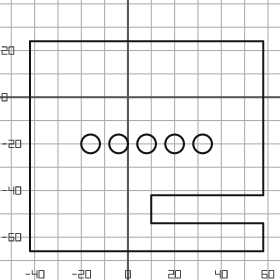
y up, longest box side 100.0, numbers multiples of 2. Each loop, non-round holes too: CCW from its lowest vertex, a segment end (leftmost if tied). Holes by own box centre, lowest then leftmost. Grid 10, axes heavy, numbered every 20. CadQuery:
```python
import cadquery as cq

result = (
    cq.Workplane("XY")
    .moveTo(-42.0, -66.0)
    .lineTo(58.0, -66.0)
    .lineTo(58.0, -54.0)
    .lineTo(10.0, -54.0)
    .lineTo(10.0, -42.0)
    .lineTo(58.0, -42.0)
    .lineTo(58.0, 24.0)
    .lineTo(-42.0, 24.0)
    .close()
    .moveTo(-16.0, -20.0)
    .circle(4.0)
    .moveTo(-4.0, -20.0)
    .circle(4.0)
    .moveTo(8.0, -20.0)
    .circle(4.0)
    .moveTo(20.0, -20.0)
    .circle(4.0)
    .moveTo(32.0, -20.0)
    .circle(4.0)
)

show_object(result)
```